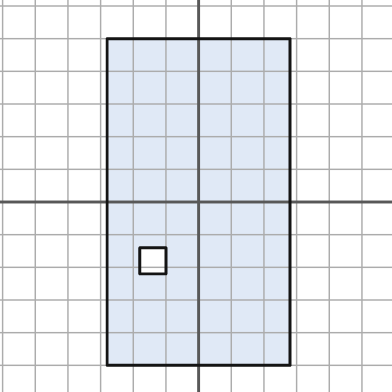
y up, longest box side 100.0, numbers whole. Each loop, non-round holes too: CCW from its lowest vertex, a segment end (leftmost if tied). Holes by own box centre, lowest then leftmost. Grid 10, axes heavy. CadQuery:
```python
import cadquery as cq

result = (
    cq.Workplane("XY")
    .moveTo(-28.0, -50.0)
    .lineTo(28.0, -50.0)
    .lineTo(28.0, 50.0)
    .lineTo(-28.0, 50.0)
    .close()
    .moveTo(-18.0, -22.0)
    .lineTo(-10.0, -22.0)
    .lineTo(-10.0, -14.0)
    .lineTo(-18.0, -14.0)
    .close()
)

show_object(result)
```